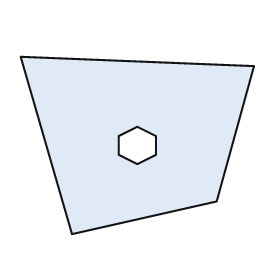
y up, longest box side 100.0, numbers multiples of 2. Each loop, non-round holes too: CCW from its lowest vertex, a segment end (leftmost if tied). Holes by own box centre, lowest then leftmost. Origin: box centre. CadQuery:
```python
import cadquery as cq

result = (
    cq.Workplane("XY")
    .moveTo(-28.0, -38.0)
    .lineTo(34.0, -24.0)
    .lineTo(50.0, 34.0)
    .lineTo(-50.0, 38.0)
    .close()
    .moveTo(0.0, -8.0)
    .lineTo(8.0, -4.0)
    .lineTo(8.0, 4.0)
    .lineTo(0.0, 8.0)
    .lineTo(-8.0, 4.0)
    .lineTo(-8.0, -4.0)
    .close()
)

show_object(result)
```